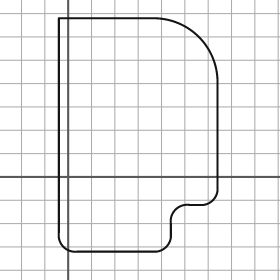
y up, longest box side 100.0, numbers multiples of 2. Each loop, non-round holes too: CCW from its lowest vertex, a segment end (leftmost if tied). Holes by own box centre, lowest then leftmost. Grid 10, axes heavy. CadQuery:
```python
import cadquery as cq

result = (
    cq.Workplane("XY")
    .moveTo(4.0, -32.0)
    .lineTo(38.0, -32.0)
    .threePointArc((42.0, -30.0), (44.0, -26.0))
    .lineTo(44.0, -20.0)
    .threePointArc((46.0, -14.0), (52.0, -12.0))
    .lineTo(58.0, -12.0)
    .threePointArc((62.0, -10.0), (64.0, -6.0))
    .lineTo(64.0, 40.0)
    .threePointArc((56.0, 60.0), (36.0, 68.0))
    .lineTo(-4.0, 68.0)
    .lineTo(-4.0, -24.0)
    .threePointArc((-2.0, -30.0), (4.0, -32.0))
    .close()
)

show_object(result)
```